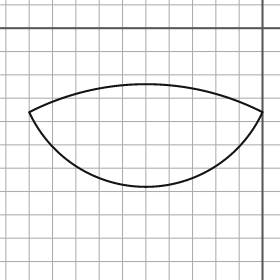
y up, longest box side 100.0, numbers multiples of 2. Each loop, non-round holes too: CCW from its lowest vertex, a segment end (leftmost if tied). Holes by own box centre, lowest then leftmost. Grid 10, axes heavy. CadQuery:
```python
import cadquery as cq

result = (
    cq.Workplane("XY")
    .moveTo(-100.0, -36.0)
    .threePointArc((-50.0, -68.0), (0.0, -36.0))
    .threePointArc((-50.0, -24.0), (-100.0, -36.0))
    .close()
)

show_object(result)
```